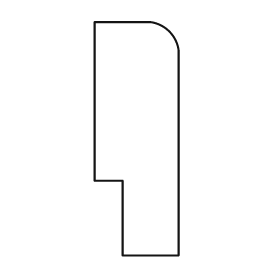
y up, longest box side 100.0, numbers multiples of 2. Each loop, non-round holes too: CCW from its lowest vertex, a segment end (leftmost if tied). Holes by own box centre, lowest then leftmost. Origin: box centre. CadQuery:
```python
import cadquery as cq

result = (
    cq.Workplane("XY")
    .moveTo(-6.0, -50.0)
    .lineTo(18.0, -50.0)
    .lineTo(18.0, 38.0)
    .threePointArc((14.0, 46.0), (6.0, 50.0))
    .lineTo(-18.0, 50.0)
    .lineTo(-18.0, -18.0)
    .lineTo(-6.0, -18.0)
    .close()
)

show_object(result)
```